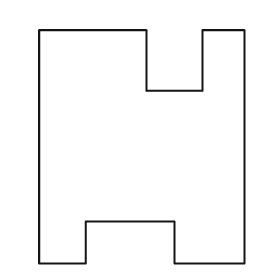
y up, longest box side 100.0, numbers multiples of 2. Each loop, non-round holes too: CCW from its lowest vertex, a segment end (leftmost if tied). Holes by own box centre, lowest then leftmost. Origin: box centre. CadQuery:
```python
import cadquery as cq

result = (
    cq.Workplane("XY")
    .moveTo(-44.0, -50.0)
    .lineTo(-24.0, -50.0)
    .lineTo(-24.0, -32.0)
    .lineTo(14.0, -32.0)
    .lineTo(14.0, -50.0)
    .lineTo(44.0, -50.0)
    .lineTo(44.0, 50.0)
    .lineTo(26.0, 50.0)
    .lineTo(26.0, 24.0)
    .lineTo(2.0, 24.0)
    .lineTo(2.0, 50.0)
    .lineTo(-44.0, 50.0)
    .close()
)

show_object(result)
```